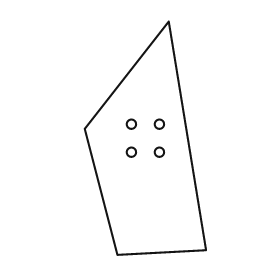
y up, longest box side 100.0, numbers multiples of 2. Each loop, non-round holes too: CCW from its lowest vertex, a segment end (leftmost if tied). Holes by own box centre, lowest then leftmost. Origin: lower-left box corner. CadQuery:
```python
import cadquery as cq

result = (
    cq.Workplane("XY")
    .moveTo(14.0, 0.0)
    .lineTo(52.0, 2.0)
    .lineTo(36.0, 100.0)
    .lineTo(0.0, 54.0)
    .close()
    .moveTo(20.0, 44.0)
    .circle(2.0)
    .moveTo(32.0, 44.0)
    .circle(2.0)
    .moveTo(20.0, 56.0)
    .circle(2.0)
    .moveTo(32.0, 56.0)
    .circle(2.0)
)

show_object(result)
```